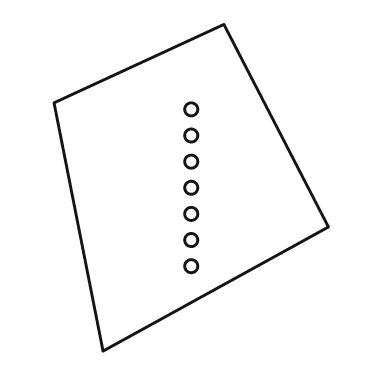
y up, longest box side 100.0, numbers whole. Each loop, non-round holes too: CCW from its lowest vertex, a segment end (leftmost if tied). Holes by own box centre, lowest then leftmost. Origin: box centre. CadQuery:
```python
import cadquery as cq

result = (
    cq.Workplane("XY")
    .moveTo(-27.0, -50.0)
    .lineTo(42.0, -12.0)
    .lineTo(10.0, 50.0)
    .lineTo(-42.0, 26.0)
    .close()
    .moveTo(0.0, -24.0)
    .circle(2.0)
    .moveTo(0.0, -16.0)
    .circle(2.0)
    .moveTo(0.0, -8.0)
    .circle(2.0)
    .moveTo(0.0, 0.0)
    .circle(2.0)
    .moveTo(0.0, 8.0)
    .circle(2.0)
    .moveTo(0.0, 16.0)
    .circle(2.0)
    .moveTo(0.0, 24.0)
    .circle(2.0)
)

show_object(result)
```